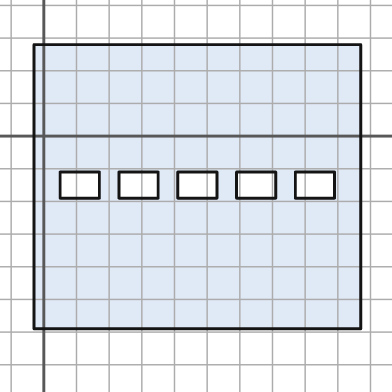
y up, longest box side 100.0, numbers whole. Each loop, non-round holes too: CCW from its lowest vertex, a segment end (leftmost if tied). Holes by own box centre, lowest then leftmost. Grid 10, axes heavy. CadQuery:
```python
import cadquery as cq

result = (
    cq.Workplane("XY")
    .moveTo(-3.0, -59.0)
    .lineTo(97.0, -59.0)
    .lineTo(97.0, 28.0)
    .lineTo(-3.0, 28.0)
    .close()
    .moveTo(5.0, -19.0)
    .lineTo(17.0, -19.0)
    .lineTo(17.0, -11.0)
    .lineTo(5.0, -11.0)
    .close()
    .moveTo(23.0, -19.0)
    .lineTo(35.0, -19.0)
    .lineTo(35.0, -11.0)
    .lineTo(23.0, -11.0)
    .close()
    .moveTo(41.0, -19.0)
    .lineTo(53.0, -19.0)
    .lineTo(53.0, -11.0)
    .lineTo(41.0, -11.0)
    .close()
    .moveTo(59.0, -19.0)
    .lineTo(71.0, -19.0)
    .lineTo(71.0, -11.0)
    .lineTo(59.0, -11.0)
    .close()
    .moveTo(77.0, -19.0)
    .lineTo(89.0, -19.0)
    .lineTo(89.0, -11.0)
    .lineTo(77.0, -11.0)
    .close()
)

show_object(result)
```